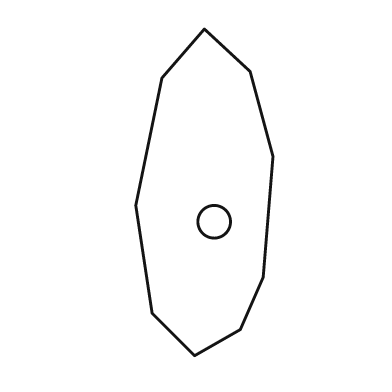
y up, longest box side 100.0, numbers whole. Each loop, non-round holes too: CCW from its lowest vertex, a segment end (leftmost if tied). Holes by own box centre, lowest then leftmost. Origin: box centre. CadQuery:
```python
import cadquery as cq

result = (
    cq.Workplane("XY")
    .moveTo(-3.0, -50.0)
    .lineTo(11.0, -42.0)
    .lineTo(18.0, -26.0)
    .lineTo(21.0, 11.0)
    .lineTo(14.0, 37.0)
    .lineTo(0.0, 50.0)
    .lineTo(-13.0, 35.0)
    .lineTo(-21.0, -4.0)
    .lineTo(-16.0, -37.0)
    .close()
    .moveTo(3.0, -9.0)
    .circle(5.0)
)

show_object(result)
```